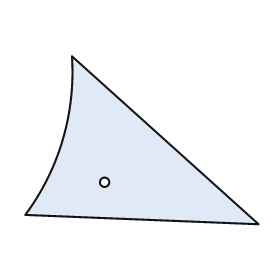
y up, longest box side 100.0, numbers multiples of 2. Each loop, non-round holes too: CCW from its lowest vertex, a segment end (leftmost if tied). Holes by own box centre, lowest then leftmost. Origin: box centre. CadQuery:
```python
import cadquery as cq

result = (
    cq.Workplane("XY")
    .moveTo(50.0, -36.0)
    .lineTo(-30.0, 36.0)
    .threePointArc((-34.0, 0.0), (-50.0, -32.0))
    .close()
    .moveTo(-16.0, -18.0)
    .circle(2.0)
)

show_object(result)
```